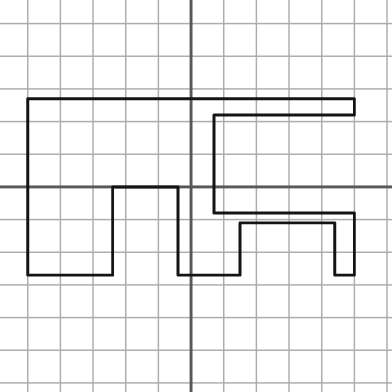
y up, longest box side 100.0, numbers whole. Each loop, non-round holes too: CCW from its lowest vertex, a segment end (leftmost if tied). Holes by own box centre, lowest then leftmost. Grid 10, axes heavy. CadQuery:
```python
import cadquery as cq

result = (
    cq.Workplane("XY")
    .moveTo(-50.0, -27.0)
    .lineTo(-24.0, -27.0)
    .lineTo(-24.0, 0.0)
    .lineTo(-4.0, 0.0)
    .lineTo(-4.0, -27.0)
    .lineTo(15.0, -27.0)
    .lineTo(15.0, -11.0)
    .lineTo(44.0, -11.0)
    .lineTo(44.0, -27.0)
    .lineTo(50.0, -27.0)
    .lineTo(50.0, -8.0)
    .lineTo(7.0, -8.0)
    .lineTo(7.0, 22.0)
    .lineTo(50.0, 22.0)
    .lineTo(50.0, 27.0)
    .lineTo(-50.0, 27.0)
    .close()
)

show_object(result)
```